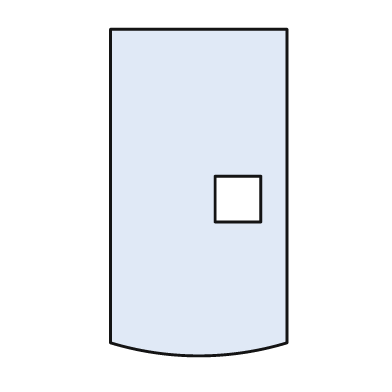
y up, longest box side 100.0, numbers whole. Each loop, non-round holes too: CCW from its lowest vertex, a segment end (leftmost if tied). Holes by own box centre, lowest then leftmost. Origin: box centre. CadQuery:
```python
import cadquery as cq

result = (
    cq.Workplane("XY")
    .moveTo(-27.0, -46.0)
    .threePointArc((0.0, -50.0), (27.0, -46.0))
    .lineTo(27.0, 50.0)
    .lineTo(-27.0, 50.0)
    .close()
    .moveTo(5.0, -9.0)
    .lineTo(19.0, -9.0)
    .lineTo(19.0, 5.0)
    .lineTo(5.0, 5.0)
    .close()
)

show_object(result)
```